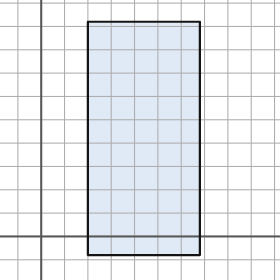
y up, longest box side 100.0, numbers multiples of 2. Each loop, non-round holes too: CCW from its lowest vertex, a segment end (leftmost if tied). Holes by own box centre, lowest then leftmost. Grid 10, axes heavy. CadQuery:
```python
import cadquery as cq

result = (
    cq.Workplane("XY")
    .moveTo(20.0, -8.0)
    .lineTo(68.0, -8.0)
    .lineTo(68.0, 92.0)
    .lineTo(20.0, 92.0)
    .close()
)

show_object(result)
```